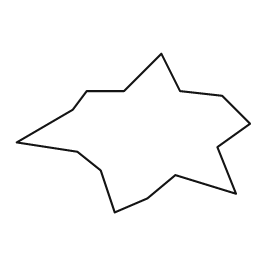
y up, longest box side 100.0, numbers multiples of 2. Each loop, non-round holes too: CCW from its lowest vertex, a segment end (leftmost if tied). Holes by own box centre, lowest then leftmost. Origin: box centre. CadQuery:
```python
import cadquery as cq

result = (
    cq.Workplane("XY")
    .moveTo(-8.0, -34.0)
    .lineTo(6.0, -28.0)
    .lineTo(18.0, -18.0)
    .lineTo(44.0, -26.0)
    .lineTo(36.0, -6.0)
    .lineTo(50.0, 4.0)
    .lineTo(38.0, 16.0)
    .lineTo(20.0, 18.0)
    .lineTo(12.0, 34.0)
    .lineTo(-4.0, 18.0)
    .lineTo(-20.0, 18.0)
    .lineTo(-26.0, 10.0)
    .lineTo(-50.0, -4.0)
    .lineTo(-24.0, -8.0)
    .lineTo(-14.0, -16.0)
    .close()
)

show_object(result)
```